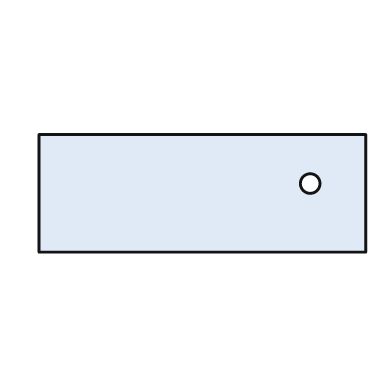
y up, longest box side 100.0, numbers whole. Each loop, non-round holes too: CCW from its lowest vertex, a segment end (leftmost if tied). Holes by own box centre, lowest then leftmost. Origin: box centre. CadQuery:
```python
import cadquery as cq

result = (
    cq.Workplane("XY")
    .moveTo(-50.0, -18.0)
    .lineTo(50.0, -18.0)
    .lineTo(50.0, 18.0)
    .lineTo(-50.0, 18.0)
    .close()
    .moveTo(33.0, 3.0)
    .circle(3.0)
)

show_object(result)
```